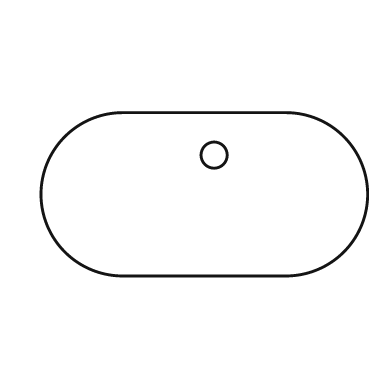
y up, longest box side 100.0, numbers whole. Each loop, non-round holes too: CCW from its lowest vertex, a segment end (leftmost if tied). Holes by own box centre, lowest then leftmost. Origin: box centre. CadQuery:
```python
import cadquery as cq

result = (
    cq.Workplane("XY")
    .moveTo(-25.0, -25.0)
    .lineTo(25.0, -25.0)
    .threePointArc((50.0, 0.0), (25.0, 25.0))
    .lineTo(-25.0, 25.0)
    .threePointArc((-50.0, 0.0), (-25.0, -25.0))
    .close()
    .moveTo(3.0, 12.0)
    .circle(4.0)
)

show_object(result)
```